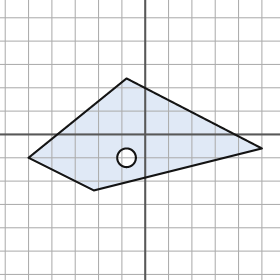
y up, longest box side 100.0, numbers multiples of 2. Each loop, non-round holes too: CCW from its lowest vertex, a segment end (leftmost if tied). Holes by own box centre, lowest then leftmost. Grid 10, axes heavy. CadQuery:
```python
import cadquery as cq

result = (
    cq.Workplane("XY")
    .moveTo(-22.0, -24.0)
    .lineTo(50.0, -6.0)
    .lineTo(-8.0, 24.0)
    .lineTo(-50.0, -10.0)
    .close()
    .moveTo(-8.0, -10.0)
    .circle(4.0)
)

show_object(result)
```